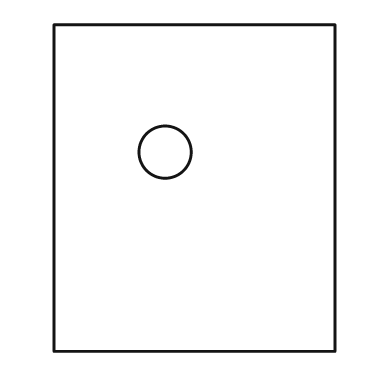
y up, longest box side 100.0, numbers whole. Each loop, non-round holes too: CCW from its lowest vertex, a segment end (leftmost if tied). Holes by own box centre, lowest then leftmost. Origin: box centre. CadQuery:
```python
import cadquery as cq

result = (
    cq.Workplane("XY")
    .moveTo(-43.0, -50.0)
    .lineTo(43.0, -50.0)
    .lineTo(43.0, 50.0)
    .lineTo(-43.0, 50.0)
    .close()
    .moveTo(-9.0, 11.0)
    .circle(8.0)
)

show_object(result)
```